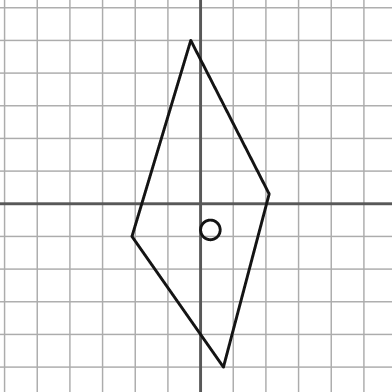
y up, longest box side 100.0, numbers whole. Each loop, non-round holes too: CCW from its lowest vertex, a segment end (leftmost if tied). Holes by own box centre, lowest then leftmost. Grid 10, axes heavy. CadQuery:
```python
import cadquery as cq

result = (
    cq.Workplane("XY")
    .moveTo(7.0, -50.0)
    .lineTo(21.0, 3.0)
    .lineTo(-3.0, 50.0)
    .lineTo(-21.0, -10.0)
    .close()
    .moveTo(3.0, -8.0)
    .circle(3.0)
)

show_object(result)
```